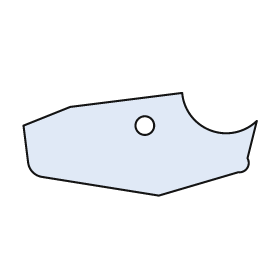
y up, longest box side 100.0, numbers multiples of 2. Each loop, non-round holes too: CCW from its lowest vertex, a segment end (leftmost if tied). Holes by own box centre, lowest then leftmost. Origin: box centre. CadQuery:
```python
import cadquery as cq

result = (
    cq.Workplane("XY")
    .moveTo(8.0, -22.0)
    .lineTo(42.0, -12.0)
    .threePointArc((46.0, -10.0), (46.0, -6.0))
    .lineTo(50.0, 10.0)
    .threePointArc((30.0, 6.0), (18.0, 22.0))
    .lineTo(-30.0, 16.0)
    .lineTo(-50.0, 8.0)
    .lineTo(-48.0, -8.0)
    .threePointArc((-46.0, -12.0), (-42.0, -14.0))
    .close()
    .moveTo(2.0, 8.0)
    .circle(4.0)
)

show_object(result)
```